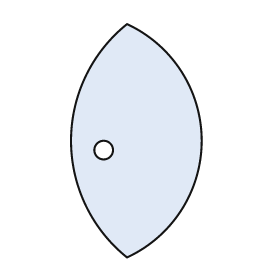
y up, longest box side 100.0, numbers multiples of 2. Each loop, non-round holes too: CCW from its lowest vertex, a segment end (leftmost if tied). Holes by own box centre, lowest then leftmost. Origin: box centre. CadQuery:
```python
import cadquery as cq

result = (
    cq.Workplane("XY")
    .moveTo(-4.0, -50.0)
    .threePointArc((28.0, 0.0), (-4.0, 50.0))
    .threePointArc((-28.0, 0.0), (-4.0, -50.0))
    .close()
    .moveTo(-14.0, -4.0)
    .circle(4.0)
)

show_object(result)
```